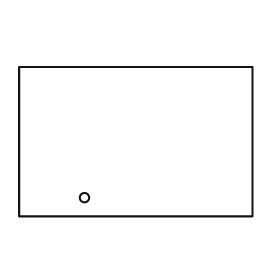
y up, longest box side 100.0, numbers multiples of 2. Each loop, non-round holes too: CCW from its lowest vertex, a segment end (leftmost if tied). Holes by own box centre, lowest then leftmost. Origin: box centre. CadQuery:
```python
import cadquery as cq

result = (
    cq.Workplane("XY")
    .moveTo(-50.0, -32.0)
    .lineTo(50.0, -32.0)
    .lineTo(50.0, 32.0)
    .lineTo(-50.0, 32.0)
    .close()
    .moveTo(-22.0, -24.0)
    .circle(2.0)
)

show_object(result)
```